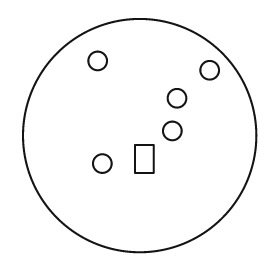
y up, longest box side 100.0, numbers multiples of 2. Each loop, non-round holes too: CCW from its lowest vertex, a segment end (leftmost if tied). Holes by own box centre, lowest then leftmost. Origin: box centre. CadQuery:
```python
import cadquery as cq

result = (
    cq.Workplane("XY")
    .moveTo(0.0, 0.0)
    .circle(50.0)
    .moveTo(-16.0, -12.0)
    .circle(4.0)
    .moveTo(-2.0, -16.0)
    .lineTo(6.0, -16.0)
    .lineTo(6.0, -4.0)
    .lineTo(-2.0, -4.0)
    .close()
    .moveTo(14.0, 2.0)
    .circle(4.0)
    .moveTo(16.0, 16.0)
    .circle(4.0)
    .moveTo(30.0, 28.0)
    .circle(4.0)
    .moveTo(-18.0, 32.0)
    .circle(4.0)
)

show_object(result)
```